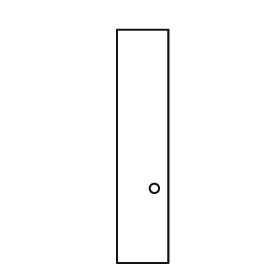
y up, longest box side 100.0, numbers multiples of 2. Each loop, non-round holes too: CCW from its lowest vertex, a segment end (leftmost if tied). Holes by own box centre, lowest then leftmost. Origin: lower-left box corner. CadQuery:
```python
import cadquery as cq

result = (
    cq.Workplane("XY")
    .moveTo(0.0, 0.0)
    .lineTo(22.0, 0.0)
    .lineTo(22.0, 100.0)
    .lineTo(0.0, 100.0)
    .close()
    .moveTo(16.0, 32.0)
    .circle(2.0)
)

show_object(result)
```